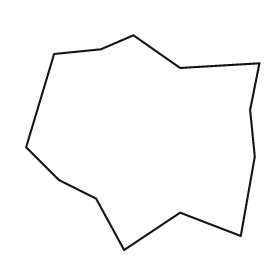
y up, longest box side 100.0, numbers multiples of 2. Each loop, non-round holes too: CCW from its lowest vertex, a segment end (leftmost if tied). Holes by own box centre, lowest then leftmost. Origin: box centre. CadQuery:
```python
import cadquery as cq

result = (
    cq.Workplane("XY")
    .moveTo(-8.0, -46.0)
    .lineTo(16.0, -30.0)
    .lineTo(42.0, -40.0)
    .lineTo(48.0, -6.0)
    .lineTo(46.0, 14.0)
    .lineTo(50.0, 34.0)
    .lineTo(16.0, 32.0)
    .lineTo(-4.0, 46.0)
    .lineTo(-18.0, 40.0)
    .lineTo(-38.0, 38.0)
    .lineTo(-50.0, -2.0)
    .lineTo(-36.0, -16.0)
    .lineTo(-20.0, -24.0)
    .close()
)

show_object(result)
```